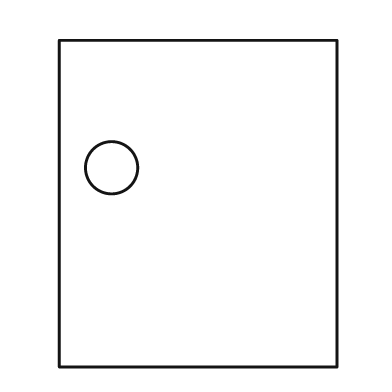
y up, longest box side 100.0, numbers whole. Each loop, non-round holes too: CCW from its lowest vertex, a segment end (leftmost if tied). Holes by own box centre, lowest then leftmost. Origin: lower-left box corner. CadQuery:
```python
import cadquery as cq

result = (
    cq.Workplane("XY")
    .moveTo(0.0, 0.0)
    .lineTo(85.0, 0.0)
    .lineTo(85.0, 100.0)
    .lineTo(0.0, 100.0)
    .close()
    .moveTo(16.0, 61.0)
    .circle(8.0)
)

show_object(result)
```